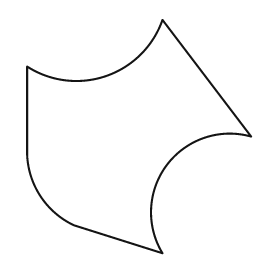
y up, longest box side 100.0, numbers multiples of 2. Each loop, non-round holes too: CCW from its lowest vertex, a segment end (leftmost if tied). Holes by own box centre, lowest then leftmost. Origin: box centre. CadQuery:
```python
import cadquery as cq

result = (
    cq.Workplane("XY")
    .moveTo(10.0, -50.0)
    .threePointArc((12.0, -12.0), (48.0, 0.0))
    .lineTo(10.0, 50.0)
    .threePointArc((-14.0, 26.0), (-48.0, 30.0))
    .lineTo(-48.0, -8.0)
    .threePointArc((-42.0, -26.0), (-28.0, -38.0))
    .close()
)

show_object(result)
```